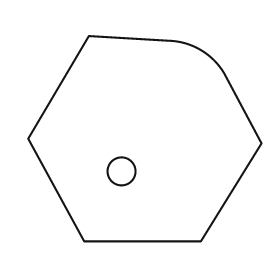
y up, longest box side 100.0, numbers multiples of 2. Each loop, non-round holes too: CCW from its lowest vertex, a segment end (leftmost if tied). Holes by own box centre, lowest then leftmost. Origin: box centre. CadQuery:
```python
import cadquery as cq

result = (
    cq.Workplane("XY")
    .moveTo(-26.0, -44.0)
    .lineTo(24.0, -44.0)
    .lineTo(50.0, -2.0)
    .lineTo(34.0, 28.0)
    .threePointArc((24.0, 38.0), (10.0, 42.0))
    .lineTo(-24.0, 44.0)
    .lineTo(-50.0, 0.0)
    .close()
    .moveTo(-10.0, -14.0)
    .circle(6.0)
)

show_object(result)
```